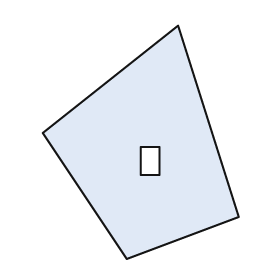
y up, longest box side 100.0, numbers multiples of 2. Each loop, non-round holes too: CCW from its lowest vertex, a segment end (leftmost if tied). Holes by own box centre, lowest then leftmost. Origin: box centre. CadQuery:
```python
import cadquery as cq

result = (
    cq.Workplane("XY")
    .moveTo(-6.0, -50.0)
    .lineTo(42.0, -32.0)
    .lineTo(16.0, 50.0)
    .lineTo(-42.0, 4.0)
    .close()
    .moveTo(0.0, -14.0)
    .lineTo(8.0, -14.0)
    .lineTo(8.0, -2.0)
    .lineTo(0.0, -2.0)
    .close()
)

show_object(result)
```